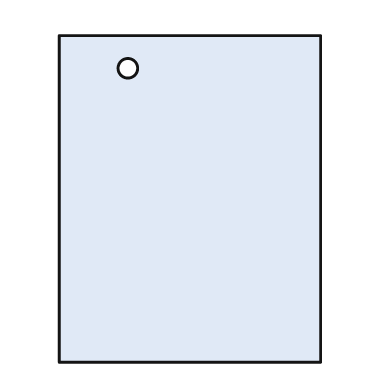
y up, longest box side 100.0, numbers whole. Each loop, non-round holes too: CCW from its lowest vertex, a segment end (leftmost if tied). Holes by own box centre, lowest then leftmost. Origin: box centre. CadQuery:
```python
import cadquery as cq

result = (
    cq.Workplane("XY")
    .moveTo(-40.0, -50.0)
    .lineTo(40.0, -50.0)
    .lineTo(40.0, 50.0)
    .lineTo(-40.0, 50.0)
    .close()
    .moveTo(-19.0, 40.0)
    .circle(3.0)
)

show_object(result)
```